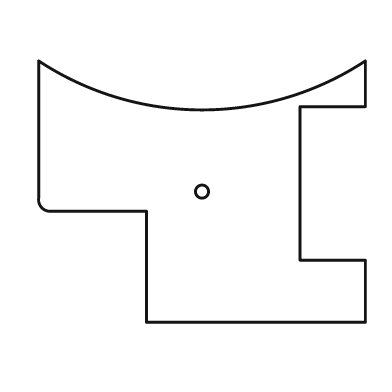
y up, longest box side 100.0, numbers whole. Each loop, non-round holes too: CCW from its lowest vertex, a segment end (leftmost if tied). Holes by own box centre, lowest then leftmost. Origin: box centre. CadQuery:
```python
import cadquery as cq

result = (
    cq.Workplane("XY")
    .moveTo(-17.0, -40.0)
    .lineTo(50.0, -40.0)
    .lineTo(50.0, -21.0)
    .lineTo(30.0, -21.0)
    .lineTo(30.0, 26.0)
    .lineTo(50.0, 26.0)
    .lineTo(50.0, 40.0)
    .threePointArc((0.0, 25.0), (-50.0, 40.0))
    .lineTo(-50.0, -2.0)
    .threePointArc((-49.0, -5.0), (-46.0, -6.0))
    .lineTo(-17.0, -6.0)
    .close()
    .moveTo(0.0, 0.0)
    .circle(2.0)
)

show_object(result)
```